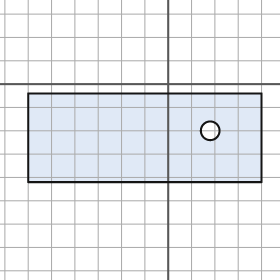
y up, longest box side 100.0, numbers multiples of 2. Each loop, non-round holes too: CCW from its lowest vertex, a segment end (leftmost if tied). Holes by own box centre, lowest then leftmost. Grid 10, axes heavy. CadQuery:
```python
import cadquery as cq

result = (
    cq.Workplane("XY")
    .moveTo(-60.0, -42.0)
    .lineTo(40.0, -42.0)
    .lineTo(40.0, -4.0)
    .lineTo(-60.0, -4.0)
    .close()
    .moveTo(18.0, -20.0)
    .circle(4.0)
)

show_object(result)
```